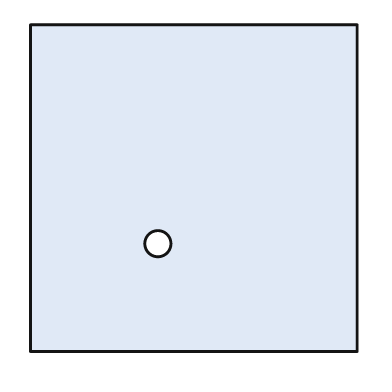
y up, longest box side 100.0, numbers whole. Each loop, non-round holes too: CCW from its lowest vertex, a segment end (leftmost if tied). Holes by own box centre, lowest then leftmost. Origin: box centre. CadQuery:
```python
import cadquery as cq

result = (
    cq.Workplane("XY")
    .moveTo(-50.0, -50.0)
    .lineTo(50.0, -50.0)
    .lineTo(50.0, 50.0)
    .lineTo(-50.0, 50.0)
    .close()
    .moveTo(-11.0, -17.0)
    .circle(4.0)
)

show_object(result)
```